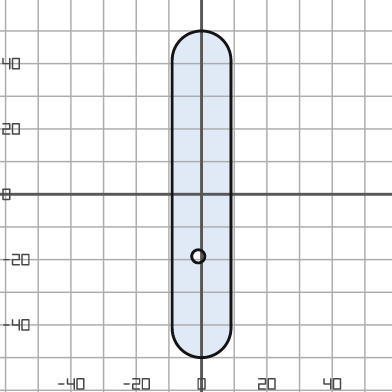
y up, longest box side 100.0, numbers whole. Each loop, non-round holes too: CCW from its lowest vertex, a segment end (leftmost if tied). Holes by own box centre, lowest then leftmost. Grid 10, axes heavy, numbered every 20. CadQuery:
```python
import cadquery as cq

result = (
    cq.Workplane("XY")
    .moveTo(-9.0, -41.0)
    .threePointArc((0.0, -50.0), (9.0, -41.0))
    .lineTo(9.0, 41.0)
    .threePointArc((0.0, 50.0), (-9.0, 41.0))
    .close()
    .moveTo(-1.0, -19.0)
    .circle(2.0)
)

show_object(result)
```